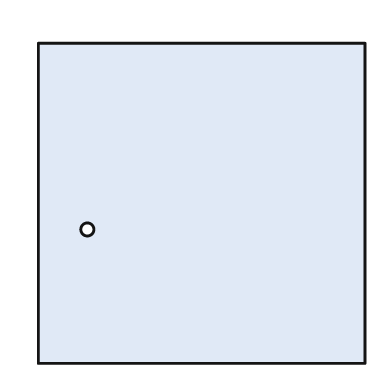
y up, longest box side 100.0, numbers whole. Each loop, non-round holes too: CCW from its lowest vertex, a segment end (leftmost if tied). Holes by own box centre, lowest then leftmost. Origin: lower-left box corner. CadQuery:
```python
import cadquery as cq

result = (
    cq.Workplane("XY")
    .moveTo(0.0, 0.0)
    .lineTo(100.0, 0.0)
    .lineTo(100.0, 98.0)
    .lineTo(0.0, 98.0)
    .close()
    .moveTo(15.0, 41.0)
    .circle(2.0)
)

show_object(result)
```